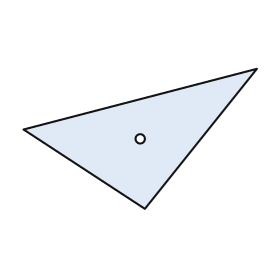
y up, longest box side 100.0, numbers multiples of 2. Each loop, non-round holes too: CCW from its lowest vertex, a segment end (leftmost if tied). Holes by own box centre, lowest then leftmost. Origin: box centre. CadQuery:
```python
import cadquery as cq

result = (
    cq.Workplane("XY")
    .moveTo(2.0, -30.0)
    .lineTo(50.0, 30.0)
    .lineTo(-50.0, 4.0)
    .close()
    .moveTo(0.0, 0.0)
    .circle(2.0)
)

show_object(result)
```